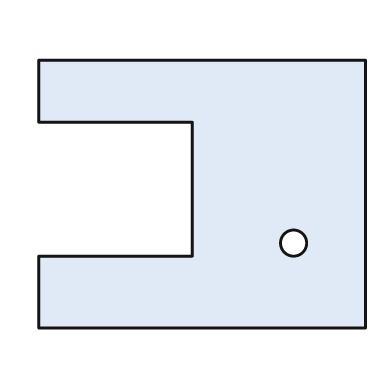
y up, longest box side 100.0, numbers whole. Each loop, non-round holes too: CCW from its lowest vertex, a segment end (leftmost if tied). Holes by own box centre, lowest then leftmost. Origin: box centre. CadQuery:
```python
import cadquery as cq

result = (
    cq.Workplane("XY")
    .moveTo(-50.0, -41.0)
    .lineTo(50.0, -41.0)
    .lineTo(50.0, 41.0)
    .lineTo(-50.0, 41.0)
    .lineTo(-50.0, 22.0)
    .lineTo(-3.0, 22.0)
    .lineTo(-3.0, -19.0)
    .lineTo(-50.0, -19.0)
    .close()
    .moveTo(28.0, -15.0)
    .circle(4.0)
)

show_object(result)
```